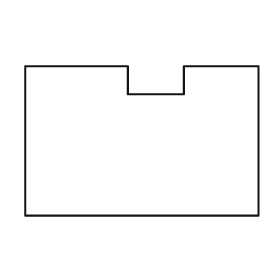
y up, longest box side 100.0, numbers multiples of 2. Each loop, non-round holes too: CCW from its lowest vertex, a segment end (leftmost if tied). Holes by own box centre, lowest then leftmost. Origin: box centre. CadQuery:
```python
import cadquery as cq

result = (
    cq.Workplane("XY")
    .moveTo(-50.0, -32.0)
    .lineTo(50.0, -32.0)
    .lineTo(50.0, 32.0)
    .lineTo(18.0, 32.0)
    .lineTo(18.0, 20.0)
    .lineTo(-6.0, 20.0)
    .lineTo(-6.0, 32.0)
    .lineTo(-50.0, 32.0)
    .close()
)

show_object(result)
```